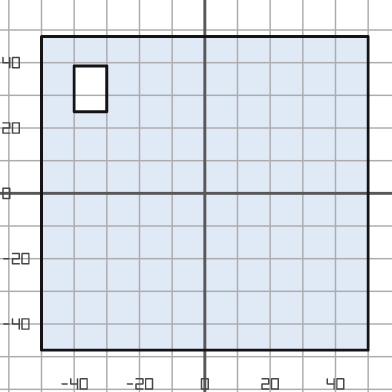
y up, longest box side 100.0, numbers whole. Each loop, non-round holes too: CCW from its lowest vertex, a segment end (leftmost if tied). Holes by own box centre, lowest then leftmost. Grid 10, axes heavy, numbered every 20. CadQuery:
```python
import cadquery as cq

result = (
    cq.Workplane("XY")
    .moveTo(-50.0, -48.0)
    .lineTo(50.0, -48.0)
    .lineTo(50.0, 48.0)
    .lineTo(-50.0, 48.0)
    .close()
    .moveTo(-40.0, 25.0)
    .lineTo(-30.0, 25.0)
    .lineTo(-30.0, 39.0)
    .lineTo(-40.0, 39.0)
    .close()
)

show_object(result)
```